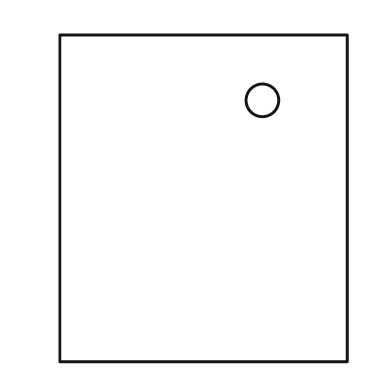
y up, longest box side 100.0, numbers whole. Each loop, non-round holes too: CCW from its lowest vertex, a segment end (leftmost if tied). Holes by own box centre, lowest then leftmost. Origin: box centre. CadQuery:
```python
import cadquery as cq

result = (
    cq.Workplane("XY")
    .moveTo(-44.0, -50.0)
    .lineTo(44.0, -50.0)
    .lineTo(44.0, 50.0)
    .lineTo(-44.0, 50.0)
    .close()
    .moveTo(18.0, 30.0)
    .circle(5.0)
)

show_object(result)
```